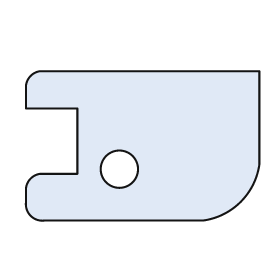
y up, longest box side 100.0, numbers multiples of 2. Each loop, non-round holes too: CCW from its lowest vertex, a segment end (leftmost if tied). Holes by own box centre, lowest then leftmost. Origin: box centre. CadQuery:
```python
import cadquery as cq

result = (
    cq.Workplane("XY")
    .moveTo(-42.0, -32.0)
    .lineTo(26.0, -32.0)
    .threePointArc((42.0, -24.0), (50.0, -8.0))
    .lineTo(50.0, 32.0)
    .lineTo(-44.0, 32.0)
    .threePointArc((-48.0, 30.0), (-50.0, 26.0))
    .lineTo(-50.0, 16.0)
    .lineTo(-28.0, 16.0)
    .lineTo(-28.0, -12.0)
    .lineTo(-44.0, -12.0)
    .threePointArc((-48.0, -14.0), (-50.0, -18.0))
    .lineTo(-50.0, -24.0)
    .threePointArc((-48.0, -30.0), (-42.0, -32.0))
    .close()
    .moveTo(-10.0, -10.0)
    .circle(8.0)
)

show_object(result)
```